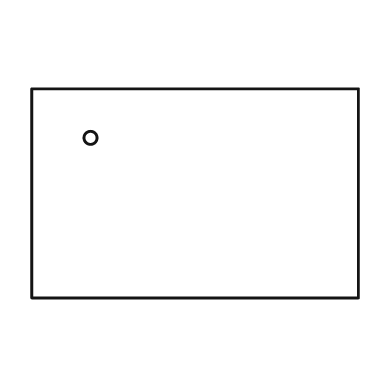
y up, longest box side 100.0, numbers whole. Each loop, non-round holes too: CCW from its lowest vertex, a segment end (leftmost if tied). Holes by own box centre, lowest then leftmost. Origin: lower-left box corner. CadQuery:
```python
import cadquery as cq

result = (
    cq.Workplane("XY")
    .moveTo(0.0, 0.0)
    .lineTo(100.0, 0.0)
    .lineTo(100.0, 64.0)
    .lineTo(0.0, 64.0)
    .close()
    .moveTo(18.0, 49.0)
    .circle(2.0)
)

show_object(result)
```